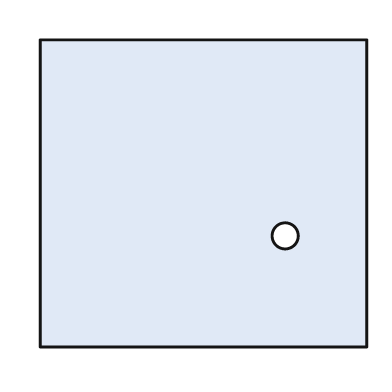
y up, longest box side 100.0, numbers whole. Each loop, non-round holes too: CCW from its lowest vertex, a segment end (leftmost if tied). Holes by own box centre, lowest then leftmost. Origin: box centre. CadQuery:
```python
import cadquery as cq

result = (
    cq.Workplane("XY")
    .moveTo(-50.0, -47.0)
    .lineTo(50.0, -47.0)
    .lineTo(50.0, 47.0)
    .lineTo(-50.0, 47.0)
    .close()
    .moveTo(25.0, -13.0)
    .circle(4.0)
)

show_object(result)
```